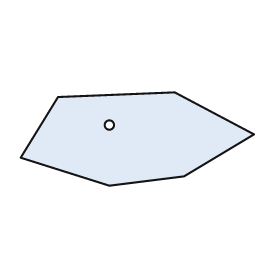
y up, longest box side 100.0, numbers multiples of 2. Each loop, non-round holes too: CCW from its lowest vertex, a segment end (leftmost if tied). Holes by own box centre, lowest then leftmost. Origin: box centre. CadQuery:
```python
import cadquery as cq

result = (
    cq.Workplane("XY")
    .moveTo(-12.0, -20.0)
    .lineTo(20.0, -16.0)
    .lineTo(50.0, 2.0)
    .lineTo(16.0, 20.0)
    .lineTo(-34.0, 18.0)
    .lineTo(-50.0, -8.0)
    .close()
    .moveTo(-12.0, 6.0)
    .circle(2.0)
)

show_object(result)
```